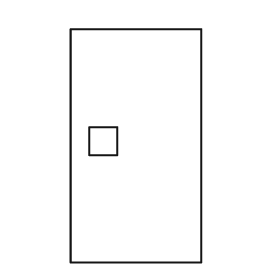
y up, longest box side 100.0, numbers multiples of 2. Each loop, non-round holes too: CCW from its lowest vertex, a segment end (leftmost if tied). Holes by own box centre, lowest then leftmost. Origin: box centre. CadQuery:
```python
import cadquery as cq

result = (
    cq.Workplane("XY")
    .moveTo(-28.0, -50.0)
    .lineTo(28.0, -50.0)
    .lineTo(28.0, 50.0)
    .lineTo(-28.0, 50.0)
    .close()
    .moveTo(-20.0, -4.0)
    .lineTo(-8.0, -4.0)
    .lineTo(-8.0, 8.0)
    .lineTo(-20.0, 8.0)
    .close()
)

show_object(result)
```